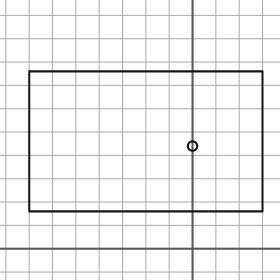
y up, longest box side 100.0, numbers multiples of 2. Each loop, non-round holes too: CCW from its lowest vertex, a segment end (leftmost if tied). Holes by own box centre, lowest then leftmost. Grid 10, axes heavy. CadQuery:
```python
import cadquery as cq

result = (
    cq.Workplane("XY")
    .moveTo(-70.0, 16.0)
    .lineTo(30.0, 16.0)
    .lineTo(30.0, 76.0)
    .lineTo(-70.0, 76.0)
    .close()
    .moveTo(0.0, 44.0)
    .circle(2.0)
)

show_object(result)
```